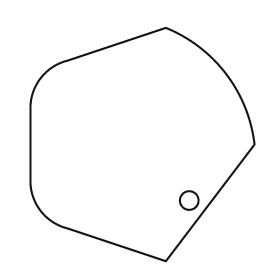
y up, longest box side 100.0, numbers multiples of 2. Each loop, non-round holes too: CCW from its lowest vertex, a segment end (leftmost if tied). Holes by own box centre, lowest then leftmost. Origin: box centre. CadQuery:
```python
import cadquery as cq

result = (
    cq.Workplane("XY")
    .moveTo(10.0, -50.0)
    .lineTo(48.0, 0.0)
    .threePointArc((36.0, 30.0), (10.0, 50.0))
    .lineTo(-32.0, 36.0)
    .threePointArc((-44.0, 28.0), (-48.0, 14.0))
    .lineTo(-48.0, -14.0)
    .threePointArc((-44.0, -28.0), (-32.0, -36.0))
    .close()
    .moveTo(20.0, -24.0)
    .circle(4.0)
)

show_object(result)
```